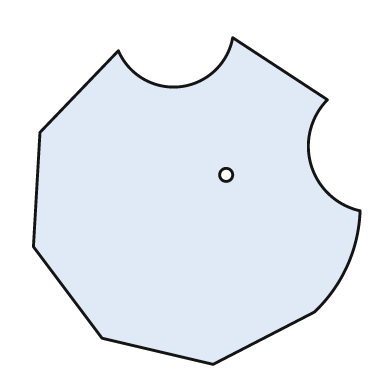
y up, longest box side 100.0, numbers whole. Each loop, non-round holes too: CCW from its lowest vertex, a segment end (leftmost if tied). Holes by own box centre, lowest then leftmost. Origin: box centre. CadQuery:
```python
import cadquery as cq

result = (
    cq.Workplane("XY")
    .moveTo(5.0, -50.0)
    .lineTo(36.0, -34.0)
    .threePointArc((46.0, -20.0), (50.0, -3.0))
    .threePointArc((35.0, 11.0), (40.0, 31.0))
    .lineTo(11.0, 50.0)
    .threePointArc((-5.0, 35.0), (-24.0, 46.0))
    .lineTo(-48.0, 21.0)
    .lineTo(-50.0, -14.0)
    .lineTo(-29.0, -42.0)
    .close()
    .moveTo(9.0, 8.0)
    .circle(2.0)
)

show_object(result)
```